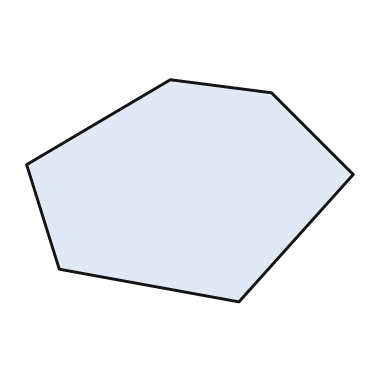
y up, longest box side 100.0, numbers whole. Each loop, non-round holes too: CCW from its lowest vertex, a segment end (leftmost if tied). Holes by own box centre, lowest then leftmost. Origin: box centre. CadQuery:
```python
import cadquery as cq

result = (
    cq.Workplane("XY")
    .moveTo(15.0, -34.0)
    .lineTo(50.0, 5.0)
    .lineTo(25.0, 30.0)
    .lineTo(-6.0, 34.0)
    .lineTo(-50.0, 8.0)
    .lineTo(-40.0, -24.0)
    .close()
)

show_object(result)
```